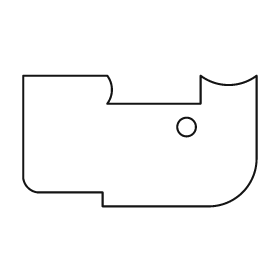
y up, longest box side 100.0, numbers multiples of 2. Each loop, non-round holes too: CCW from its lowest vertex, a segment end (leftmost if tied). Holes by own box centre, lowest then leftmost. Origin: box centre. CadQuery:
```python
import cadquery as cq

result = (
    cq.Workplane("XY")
    .moveTo(-16.0, -28.0)
    .lineTo(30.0, -28.0)
    .threePointArc((44.0, -22.0), (50.0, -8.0))
    .lineTo(50.0, 28.0)
    .threePointArc((38.0, 24.0), (26.0, 28.0))
    .lineTo(26.0, 16.0)
    .lineTo(-14.0, 16.0)
    .threePointArc((-12.0, 22.0), (-14.0, 28.0))
    .lineTo(-50.0, 28.0)
    .lineTo(-50.0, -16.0)
    .threePointArc((-48.0, -20.0), (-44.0, -22.0))
    .lineTo(-16.0, -22.0)
    .close()
    .moveTo(20.0, 6.0)
    .circle(4.0)
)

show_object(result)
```